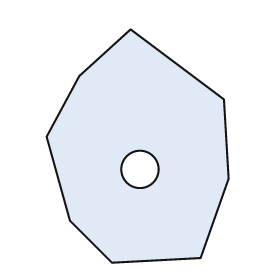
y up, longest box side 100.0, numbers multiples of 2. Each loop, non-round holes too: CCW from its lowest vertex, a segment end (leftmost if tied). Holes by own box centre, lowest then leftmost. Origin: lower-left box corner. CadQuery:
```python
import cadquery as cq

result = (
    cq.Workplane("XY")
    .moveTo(28.0, 0.0)
    .lineTo(66.0, 2.0)
    .lineTo(78.0, 36.0)
    .lineTo(76.0, 70.0)
    .lineTo(36.0, 100.0)
    .lineTo(14.0, 80.0)
    .lineTo(0.0, 54.0)
    .lineTo(10.0, 18.0)
    .close()
    .moveTo(40.0, 40.0)
    .circle(8.0)
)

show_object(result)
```